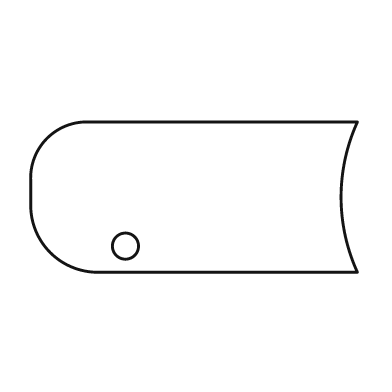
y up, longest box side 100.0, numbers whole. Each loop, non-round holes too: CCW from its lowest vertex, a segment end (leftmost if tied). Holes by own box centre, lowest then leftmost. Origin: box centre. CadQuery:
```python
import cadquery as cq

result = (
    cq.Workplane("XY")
    .moveTo(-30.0, -23.0)
    .lineTo(50.0, -23.0)
    .threePointArc((45.0, 0.0), (50.0, 23.0))
    .lineTo(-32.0, 23.0)
    .threePointArc((-45.0, 18.0), (-50.0, 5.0))
    .lineTo(-50.0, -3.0)
    .threePointArc((-44.0, -17.0), (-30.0, -23.0))
    .close()
    .moveTo(-21.0, -15.0)
    .circle(4.0)
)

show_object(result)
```